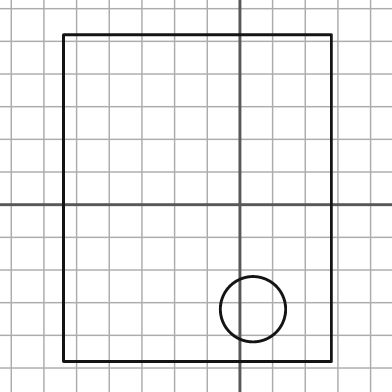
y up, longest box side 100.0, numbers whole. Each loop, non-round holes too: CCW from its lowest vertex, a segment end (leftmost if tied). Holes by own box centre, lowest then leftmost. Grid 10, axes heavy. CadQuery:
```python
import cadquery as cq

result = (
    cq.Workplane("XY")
    .moveTo(-54.0, -48.0)
    .lineTo(28.0, -48.0)
    .lineTo(28.0, 52.0)
    .lineTo(-54.0, 52.0)
    .close()
    .moveTo(4.0, -32.0)
    .circle(10.0)
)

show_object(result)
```